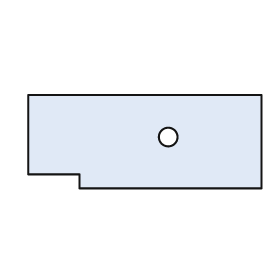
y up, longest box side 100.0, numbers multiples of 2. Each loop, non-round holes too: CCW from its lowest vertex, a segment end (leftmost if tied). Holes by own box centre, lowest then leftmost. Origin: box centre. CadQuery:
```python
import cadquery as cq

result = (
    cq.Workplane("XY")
    .moveTo(-28.0, -20.0)
    .lineTo(50.0, -20.0)
    .lineTo(50.0, 20.0)
    .lineTo(-50.0, 20.0)
    .lineTo(-50.0, -14.0)
    .lineTo(-28.0, -14.0)
    .close()
    .moveTo(10.0, 2.0)
    .circle(4.0)
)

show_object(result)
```